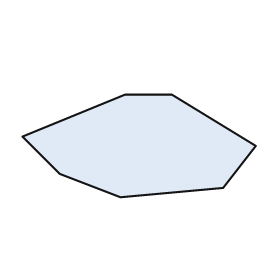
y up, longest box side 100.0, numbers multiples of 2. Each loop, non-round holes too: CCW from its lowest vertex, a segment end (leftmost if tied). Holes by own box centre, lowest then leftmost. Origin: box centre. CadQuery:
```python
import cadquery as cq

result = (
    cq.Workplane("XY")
    .moveTo(-8.0, -22.0)
    .lineTo(36.0, -18.0)
    .lineTo(50.0, 0.0)
    .lineTo(14.0, 22.0)
    .lineTo(-6.0, 22.0)
    .lineTo(-50.0, 4.0)
    .lineTo(-34.0, -12.0)
    .close()
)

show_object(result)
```